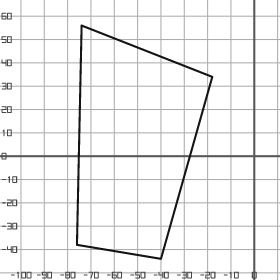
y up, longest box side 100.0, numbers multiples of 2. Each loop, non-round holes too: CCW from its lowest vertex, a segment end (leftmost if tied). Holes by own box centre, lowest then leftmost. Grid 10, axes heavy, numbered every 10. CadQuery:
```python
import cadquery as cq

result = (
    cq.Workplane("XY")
    .moveTo(-40.0, -44.0)
    .lineTo(-18.0, 34.0)
    .lineTo(-74.0, 56.0)
    .lineTo(-76.0, -38.0)
    .close()
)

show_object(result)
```